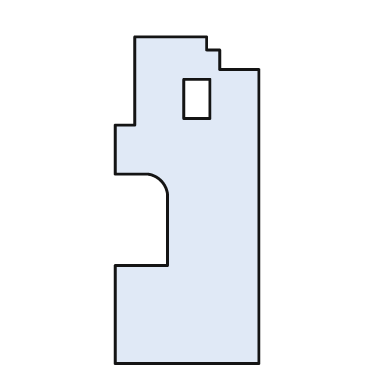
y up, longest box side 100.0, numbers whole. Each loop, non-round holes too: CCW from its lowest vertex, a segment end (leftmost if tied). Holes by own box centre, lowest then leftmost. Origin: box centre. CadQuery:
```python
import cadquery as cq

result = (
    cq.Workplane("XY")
    .moveTo(-22.0, -50.0)
    .lineTo(22.0, -50.0)
    .lineTo(22.0, 40.0)
    .lineTo(10.0, 40.0)
    .lineTo(10.0, 46.0)
    .lineTo(6.0, 46.0)
    .lineTo(6.0, 50.0)
    .lineTo(-16.0, 50.0)
    .lineTo(-16.0, 23.0)
    .lineTo(-22.0, 23.0)
    .lineTo(-22.0, 8.0)
    .lineTo(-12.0, 8.0)
    .threePointArc((-8.0, 6.0), (-6.0, 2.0))
    .lineTo(-6.0, -20.0)
    .lineTo(-22.0, -20.0)
    .close()
    .moveTo(-1.0, 25.0)
    .lineTo(7.0, 25.0)
    .lineTo(7.0, 37.0)
    .lineTo(-1.0, 37.0)
    .close()
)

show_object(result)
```